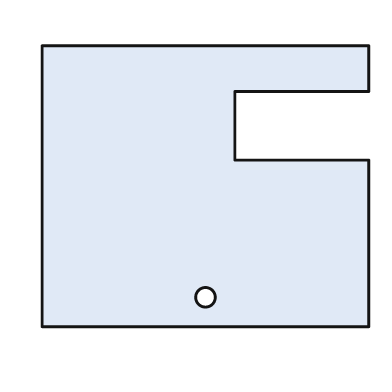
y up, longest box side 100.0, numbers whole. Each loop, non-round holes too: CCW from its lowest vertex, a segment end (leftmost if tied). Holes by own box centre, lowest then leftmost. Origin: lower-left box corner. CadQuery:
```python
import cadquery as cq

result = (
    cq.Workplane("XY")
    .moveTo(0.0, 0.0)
    .lineTo(100.0, 0.0)
    .lineTo(100.0, 51.0)
    .lineTo(59.0, 51.0)
    .lineTo(59.0, 72.0)
    .lineTo(100.0, 72.0)
    .lineTo(100.0, 86.0)
    .lineTo(0.0, 86.0)
    .close()
    .moveTo(50.0, 9.0)
    .circle(3.0)
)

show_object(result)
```